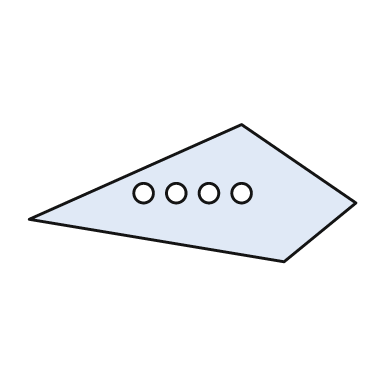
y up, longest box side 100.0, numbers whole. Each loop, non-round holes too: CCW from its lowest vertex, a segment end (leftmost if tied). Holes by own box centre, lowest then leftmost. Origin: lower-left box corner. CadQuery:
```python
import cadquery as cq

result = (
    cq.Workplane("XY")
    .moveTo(78.0, 0.0)
    .lineTo(100.0, 18.0)
    .lineTo(65.0, 42.0)
    .lineTo(0.0, 13.0)
    .close()
    .moveTo(35.0, 21.0)
    .circle(3.0)
    .moveTo(45.0, 21.0)
    .circle(3.0)
    .moveTo(55.0, 21.0)
    .circle(3.0)
    .moveTo(65.0, 21.0)
    .circle(3.0)
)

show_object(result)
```